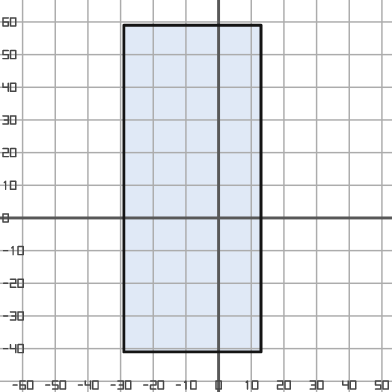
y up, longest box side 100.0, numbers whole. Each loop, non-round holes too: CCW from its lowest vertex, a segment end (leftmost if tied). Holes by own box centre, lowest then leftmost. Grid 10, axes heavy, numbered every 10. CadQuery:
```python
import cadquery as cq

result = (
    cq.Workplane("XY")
    .moveTo(-29.0, -41.0)
    .lineTo(13.0, -41.0)
    .lineTo(13.0, 59.0)
    .lineTo(-29.0, 59.0)
    .close()
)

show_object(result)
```